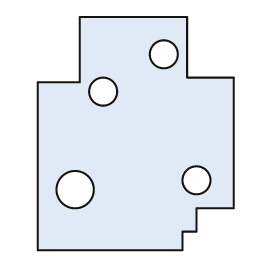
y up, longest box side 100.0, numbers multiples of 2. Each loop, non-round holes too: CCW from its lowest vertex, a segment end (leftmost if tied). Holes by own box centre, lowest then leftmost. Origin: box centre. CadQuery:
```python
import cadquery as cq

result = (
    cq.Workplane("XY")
    .moveTo(-42.0, -50.0)
    .lineTo(20.0, -50.0)
    .lineTo(20.0, -42.0)
    .lineTo(26.0, -42.0)
    .lineTo(26.0, -32.0)
    .lineTo(42.0, -32.0)
    .lineTo(42.0, 24.0)
    .lineTo(22.0, 24.0)
    .lineTo(22.0, 50.0)
    .lineTo(-24.0, 50.0)
    .lineTo(-24.0, 22.0)
    .lineTo(-42.0, 22.0)
    .close()
    .moveTo(-26.0, -24.0)
    .circle(8.0)
    .moveTo(26.0, -20.0)
    .circle(6.0)
    .moveTo(-14.0, 18.0)
    .circle(6.0)
    .moveTo(12.0, 34.0)
    .circle(6.0)
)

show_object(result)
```